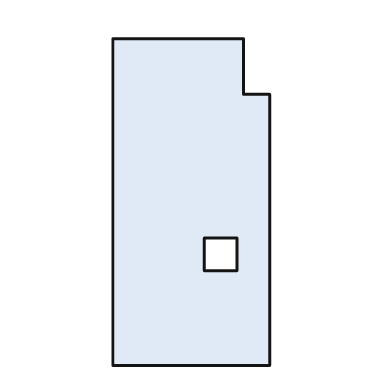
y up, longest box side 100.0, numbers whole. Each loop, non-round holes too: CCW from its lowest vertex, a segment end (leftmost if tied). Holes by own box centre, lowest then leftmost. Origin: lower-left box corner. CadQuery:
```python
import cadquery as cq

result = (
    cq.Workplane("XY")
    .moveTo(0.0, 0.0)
    .lineTo(48.0, 0.0)
    .lineTo(48.0, 83.0)
    .lineTo(40.0, 83.0)
    .lineTo(40.0, 100.0)
    .lineTo(0.0, 100.0)
    .close()
    .moveTo(28.0, 29.0)
    .lineTo(38.0, 29.0)
    .lineTo(38.0, 39.0)
    .lineTo(28.0, 39.0)
    .close()
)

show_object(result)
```